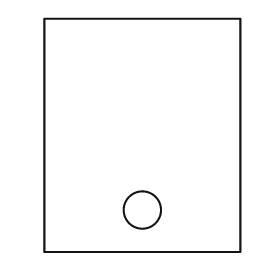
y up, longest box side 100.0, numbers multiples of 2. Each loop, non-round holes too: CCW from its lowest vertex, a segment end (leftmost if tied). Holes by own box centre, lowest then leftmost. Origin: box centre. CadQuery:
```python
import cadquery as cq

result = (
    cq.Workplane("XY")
    .moveTo(-42.0, -50.0)
    .lineTo(42.0, -50.0)
    .lineTo(42.0, 50.0)
    .lineTo(-42.0, 50.0)
    .close()
    .moveTo(0.0, -32.0)
    .circle(8.0)
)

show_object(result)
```